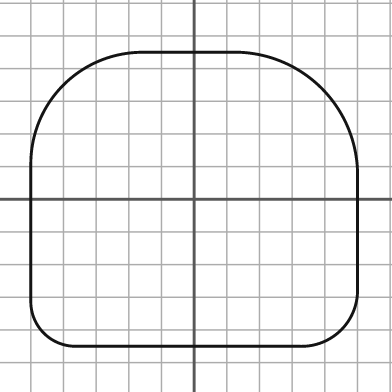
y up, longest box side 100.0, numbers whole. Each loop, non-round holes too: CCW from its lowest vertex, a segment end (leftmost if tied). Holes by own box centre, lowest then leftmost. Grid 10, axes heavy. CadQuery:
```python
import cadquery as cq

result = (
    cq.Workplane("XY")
    .moveTo(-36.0, -45.0)
    .lineTo(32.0, -45.0)
    .threePointArc((45.0, -40.0), (50.0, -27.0))
    .lineTo(50.0, 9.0)
    .threePointArc((39.0, 34.0), (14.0, 45.0))
    .lineTo(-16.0, 45.0)
    .threePointArc((-40.0, 35.0), (-50.0, 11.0))
    .lineTo(-50.0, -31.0)
    .threePointArc((-46.0, -41.0), (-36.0, -45.0))
    .close()
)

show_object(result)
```